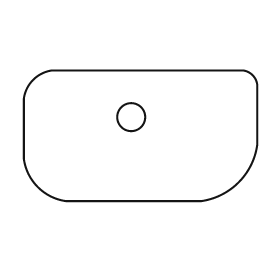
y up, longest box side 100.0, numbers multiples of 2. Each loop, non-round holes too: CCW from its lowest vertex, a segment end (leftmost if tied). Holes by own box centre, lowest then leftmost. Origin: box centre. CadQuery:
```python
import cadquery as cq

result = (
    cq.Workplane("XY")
    .moveTo(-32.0, -28.0)
    .lineTo(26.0, -28.0)
    .threePointArc((42.0, -20.0), (50.0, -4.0))
    .lineTo(50.0, 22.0)
    .threePointArc((48.0, 26.0), (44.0, 28.0))
    .lineTo(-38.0, 28.0)
    .threePointArc((-46.0, 24.0), (-50.0, 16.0))
    .lineTo(-50.0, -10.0)
    .threePointArc((-44.0, -22.0), (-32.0, -28.0))
    .close()
    .moveTo(-4.0, 8.0)
    .circle(6.0)
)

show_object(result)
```